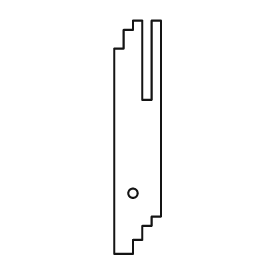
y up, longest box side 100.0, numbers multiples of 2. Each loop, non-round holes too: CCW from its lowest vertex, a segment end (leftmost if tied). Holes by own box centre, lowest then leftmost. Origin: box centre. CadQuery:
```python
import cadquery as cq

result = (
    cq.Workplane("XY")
    .moveTo(-10.0, -50.0)
    .lineTo(-2.0, -50.0)
    .lineTo(-2.0, -44.0)
    .lineTo(2.0, -44.0)
    .lineTo(2.0, -38.0)
    .lineTo(6.0, -38.0)
    .lineTo(6.0, -34.0)
    .lineTo(10.0, -34.0)
    .lineTo(10.0, 50.0)
    .lineTo(6.0, 50.0)
    .lineTo(6.0, 16.0)
    .lineTo(2.0, 16.0)
    .lineTo(2.0, 50.0)
    .lineTo(-2.0, 50.0)
    .lineTo(-2.0, 46.0)
    .lineTo(-6.0, 46.0)
    .lineTo(-6.0, 38.0)
    .lineTo(-10.0, 38.0)
    .close()
    .moveTo(-2.0, -24.0)
    .circle(2.0)
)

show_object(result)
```